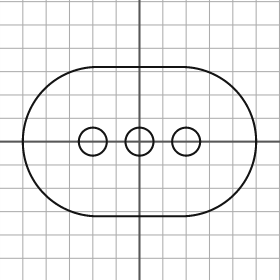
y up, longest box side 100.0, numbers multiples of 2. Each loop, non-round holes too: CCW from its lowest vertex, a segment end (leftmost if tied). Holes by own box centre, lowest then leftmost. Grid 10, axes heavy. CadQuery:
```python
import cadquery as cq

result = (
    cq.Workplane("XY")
    .moveTo(-18.0, -32.0)
    .lineTo(18.0, -32.0)
    .threePointArc((50.0, 0.0), (18.0, 32.0))
    .lineTo(-18.0, 32.0)
    .threePointArc((-50.0, 0.0), (-18.0, -32.0))
    .close()
    .moveTo(-20.0, 0.0)
    .circle(6.0)
    .moveTo(0.0, 0.0)
    .circle(6.0)
    .moveTo(20.0, 0.0)
    .circle(6.0)
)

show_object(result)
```